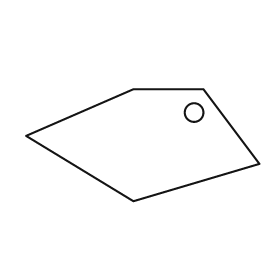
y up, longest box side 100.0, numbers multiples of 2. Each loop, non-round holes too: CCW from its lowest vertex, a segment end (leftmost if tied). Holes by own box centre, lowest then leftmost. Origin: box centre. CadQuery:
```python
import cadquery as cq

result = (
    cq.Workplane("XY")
    .moveTo(-4.0, -24.0)
    .lineTo(50.0, -8.0)
    .lineTo(26.0, 24.0)
    .lineTo(-4.0, 24.0)
    .lineTo(-50.0, 4.0)
    .close()
    .moveTo(22.0, 14.0)
    .circle(4.0)
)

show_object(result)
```